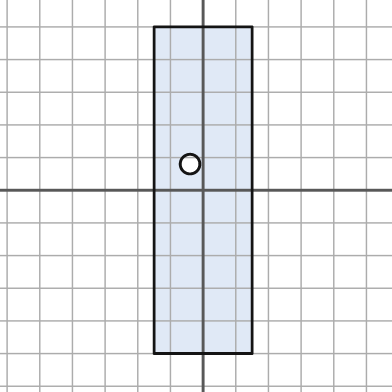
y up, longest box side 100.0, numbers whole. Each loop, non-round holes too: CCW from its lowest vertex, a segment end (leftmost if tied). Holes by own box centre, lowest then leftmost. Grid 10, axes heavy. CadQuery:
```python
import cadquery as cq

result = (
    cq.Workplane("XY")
    .moveTo(-15.0, -50.0)
    .lineTo(15.0, -50.0)
    .lineTo(15.0, 50.0)
    .lineTo(-15.0, 50.0)
    .close()
    .moveTo(-4.0, 8.0)
    .circle(3.0)
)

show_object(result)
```